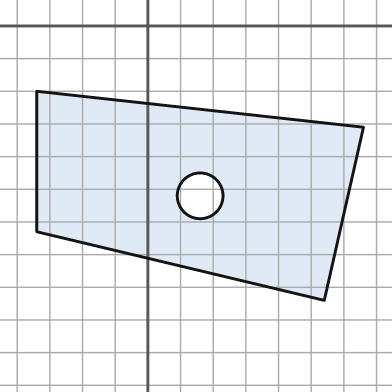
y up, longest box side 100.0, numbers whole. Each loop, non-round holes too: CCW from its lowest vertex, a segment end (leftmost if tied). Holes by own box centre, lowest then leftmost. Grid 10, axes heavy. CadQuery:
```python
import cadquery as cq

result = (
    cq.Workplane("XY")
    .moveTo(54.0, -84.0)
    .lineTo(66.0, -31.0)
    .lineTo(-34.0, -20.0)
    .lineTo(-34.0, -63.0)
    .close()
    .moveTo(16.0, -52.0)
    .circle(7.0)
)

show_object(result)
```